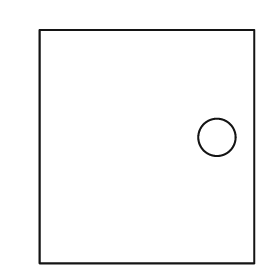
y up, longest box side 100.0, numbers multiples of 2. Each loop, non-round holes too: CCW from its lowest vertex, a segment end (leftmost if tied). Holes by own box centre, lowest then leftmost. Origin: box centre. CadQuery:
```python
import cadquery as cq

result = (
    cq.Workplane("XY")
    .moveTo(-46.0, -50.0)
    .lineTo(46.0, -50.0)
    .lineTo(46.0, 50.0)
    .lineTo(-46.0, 50.0)
    .close()
    .moveTo(30.0, 4.0)
    .circle(8.0)
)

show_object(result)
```